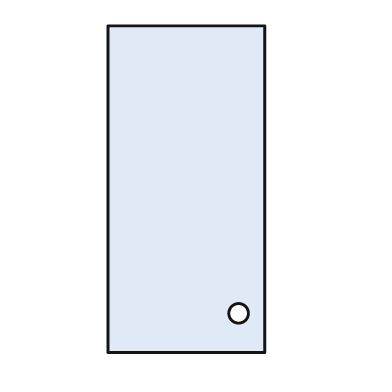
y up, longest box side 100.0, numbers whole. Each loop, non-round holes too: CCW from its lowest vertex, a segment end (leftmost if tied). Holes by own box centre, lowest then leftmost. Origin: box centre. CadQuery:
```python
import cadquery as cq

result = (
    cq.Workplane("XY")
    .moveTo(-24.0, -50.0)
    .lineTo(24.0, -50.0)
    .lineTo(24.0, 50.0)
    .lineTo(-24.0, 50.0)
    .close()
    .moveTo(16.0, -38.0)
    .circle(3.0)
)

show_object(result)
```